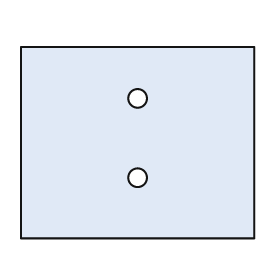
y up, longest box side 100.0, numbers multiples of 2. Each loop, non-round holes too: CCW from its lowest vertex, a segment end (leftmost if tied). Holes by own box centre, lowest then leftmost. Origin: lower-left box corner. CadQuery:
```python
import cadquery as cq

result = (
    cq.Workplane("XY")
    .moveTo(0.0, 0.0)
    .lineTo(100.0, 0.0)
    .lineTo(100.0, 82.0)
    .lineTo(0.0, 82.0)
    .close()
    .moveTo(50.0, 26.0)
    .circle(4.0)
    .moveTo(50.0, 60.0)
    .circle(4.0)
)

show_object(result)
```